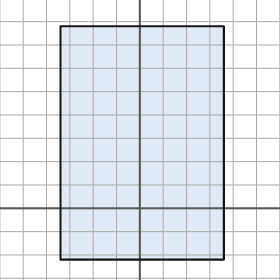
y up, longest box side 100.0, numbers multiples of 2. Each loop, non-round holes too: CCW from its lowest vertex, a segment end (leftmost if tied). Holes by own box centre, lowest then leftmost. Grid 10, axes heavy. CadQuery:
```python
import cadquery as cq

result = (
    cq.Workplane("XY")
    .moveTo(-34.0, -22.0)
    .lineTo(36.0, -22.0)
    .lineTo(36.0, 78.0)
    .lineTo(-34.0, 78.0)
    .close()
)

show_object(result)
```